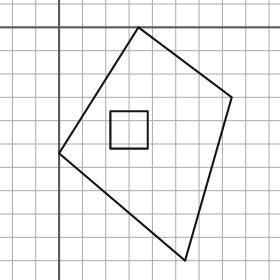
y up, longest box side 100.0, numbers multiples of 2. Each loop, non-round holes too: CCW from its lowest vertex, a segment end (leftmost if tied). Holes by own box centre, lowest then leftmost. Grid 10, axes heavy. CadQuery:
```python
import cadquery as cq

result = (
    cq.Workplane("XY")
    .moveTo(54.0, -100.0)
    .lineTo(74.0, -30.0)
    .lineTo(34.0, 0.0)
    .lineTo(0.0, -54.0)
    .close()
    .moveTo(22.0, -52.0)
    .lineTo(38.0, -52.0)
    .lineTo(38.0, -36.0)
    .lineTo(22.0, -36.0)
    .close()
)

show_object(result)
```